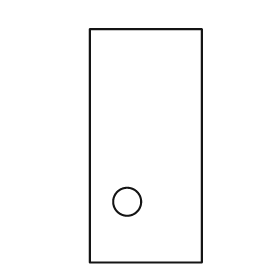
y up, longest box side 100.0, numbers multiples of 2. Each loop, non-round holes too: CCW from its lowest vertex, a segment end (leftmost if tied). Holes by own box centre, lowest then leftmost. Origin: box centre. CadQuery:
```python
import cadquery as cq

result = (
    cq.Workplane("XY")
    .moveTo(-24.0, -50.0)
    .lineTo(24.0, -50.0)
    .lineTo(24.0, 50.0)
    .lineTo(-24.0, 50.0)
    .close()
    .moveTo(-8.0, -24.0)
    .circle(6.0)
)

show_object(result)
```